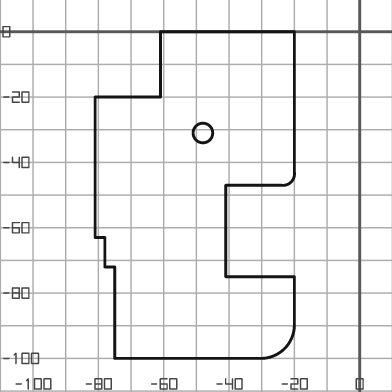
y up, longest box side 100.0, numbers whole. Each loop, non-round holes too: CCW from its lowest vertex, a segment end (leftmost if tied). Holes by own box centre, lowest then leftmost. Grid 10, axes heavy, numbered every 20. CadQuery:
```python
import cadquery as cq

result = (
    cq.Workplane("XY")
    .moveTo(-75.0, -100.0)
    .lineTo(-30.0, -100.0)
    .threePointArc((-23.0, -97.0), (-20.0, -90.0))
    .lineTo(-20.0, -75.0)
    .lineTo(-41.0, -75.0)
    .lineTo(-41.0, -47.0)
    .lineTo(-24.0, -47.0)
    .threePointArc((-21.0, -46.0), (-20.0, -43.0))
    .lineTo(-20.0, 0.0)
    .lineTo(-61.0, 0.0)
    .lineTo(-61.0, -20.0)
    .lineTo(-81.0, -20.0)
    .lineTo(-81.0, -63.0)
    .lineTo(-78.0, -63.0)
    .lineTo(-78.0, -72.0)
    .lineTo(-75.0, -72.0)
    .close()
    .moveTo(-48.0, -31.0)
    .circle(3.0)
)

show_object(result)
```